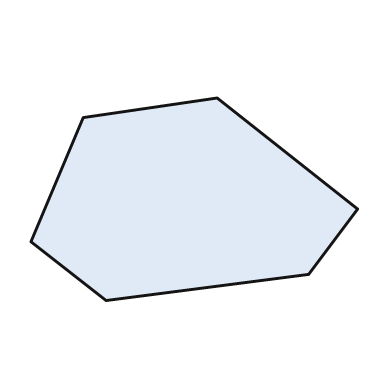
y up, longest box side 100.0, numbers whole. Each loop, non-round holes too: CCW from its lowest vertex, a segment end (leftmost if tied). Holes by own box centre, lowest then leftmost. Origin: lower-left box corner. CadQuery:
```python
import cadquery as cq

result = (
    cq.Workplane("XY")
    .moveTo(23.0, 0.0)
    .lineTo(85.0, 8.0)
    .lineTo(100.0, 28.0)
    .lineTo(57.0, 62.0)
    .lineTo(16.0, 56.0)
    .lineTo(0.0, 18.0)
    .close()
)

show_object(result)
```